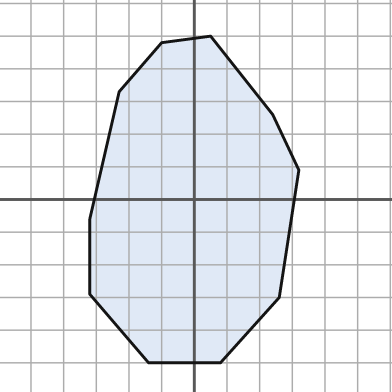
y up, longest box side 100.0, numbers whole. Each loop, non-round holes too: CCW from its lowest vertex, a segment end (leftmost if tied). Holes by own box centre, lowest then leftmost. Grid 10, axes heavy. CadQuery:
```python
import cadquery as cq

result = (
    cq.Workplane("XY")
    .moveTo(-14.0, -50.0)
    .lineTo(8.0, -50.0)
    .lineTo(26.0, -30.0)
    .lineTo(32.0, 9.0)
    .lineTo(24.0, 26.0)
    .lineTo(5.0, 50.0)
    .lineTo(-10.0, 48.0)
    .lineTo(-23.0, 33.0)
    .lineTo(-32.0, -6.0)
    .lineTo(-32.0, -29.0)
    .close()
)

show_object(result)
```